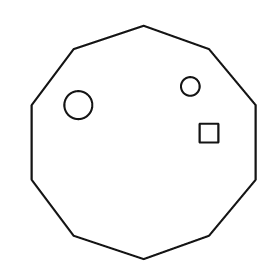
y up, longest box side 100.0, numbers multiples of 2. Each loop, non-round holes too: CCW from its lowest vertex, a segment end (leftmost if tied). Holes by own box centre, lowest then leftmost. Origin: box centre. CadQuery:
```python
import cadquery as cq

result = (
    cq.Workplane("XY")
    .moveTo(0.0, -50.0)
    .lineTo(28.0, -40.0)
    .lineTo(48.0, -16.0)
    .lineTo(48.0, 16.0)
    .lineTo(28.0, 40.0)
    .lineTo(0.0, 50.0)
    .lineTo(-30.0, 40.0)
    .lineTo(-48.0, 16.0)
    .lineTo(-48.0, -16.0)
    .lineTo(-30.0, -40.0)
    .close()
    .moveTo(24.0, 0.0)
    .lineTo(32.0, 0.0)
    .lineTo(32.0, 8.0)
    .lineTo(24.0, 8.0)
    .close()
    .moveTo(-28.0, 16.0)
    .circle(6.0)
    .moveTo(20.0, 24.0)
    .circle(4.0)
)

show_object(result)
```